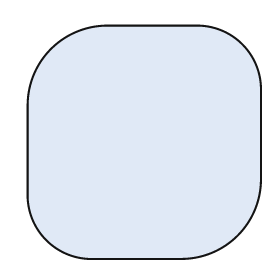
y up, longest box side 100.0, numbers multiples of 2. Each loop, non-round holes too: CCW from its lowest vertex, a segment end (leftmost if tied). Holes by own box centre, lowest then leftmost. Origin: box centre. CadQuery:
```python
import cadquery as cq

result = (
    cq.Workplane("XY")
    .moveTo(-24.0, -50.0)
    .lineTo(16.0, -50.0)
    .threePointArc((40.0, -40.0), (50.0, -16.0))
    .lineTo(50.0, 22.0)
    .threePointArc((42.0, 42.0), (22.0, 50.0))
    .lineTo(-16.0, 50.0)
    .threePointArc((-40.0, 40.0), (-50.0, 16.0))
    .lineTo(-50.0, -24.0)
    .threePointArc((-42.0, -42.0), (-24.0, -50.0))
    .close()
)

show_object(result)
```